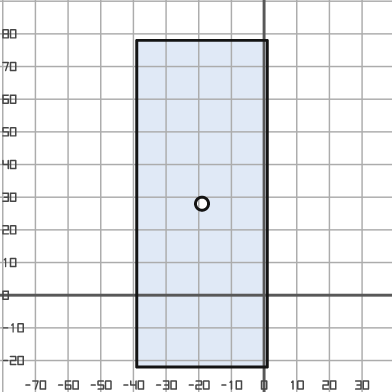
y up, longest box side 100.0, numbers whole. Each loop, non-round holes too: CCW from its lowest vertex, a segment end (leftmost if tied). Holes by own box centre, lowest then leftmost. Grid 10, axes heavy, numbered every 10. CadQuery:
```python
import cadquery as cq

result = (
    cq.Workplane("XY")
    .moveTo(-39.0, -22.0)
    .lineTo(1.0, -22.0)
    .lineTo(1.0, 78.0)
    .lineTo(-39.0, 78.0)
    .close()
    .moveTo(-19.0, 28.0)
    .circle(2.0)
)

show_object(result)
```